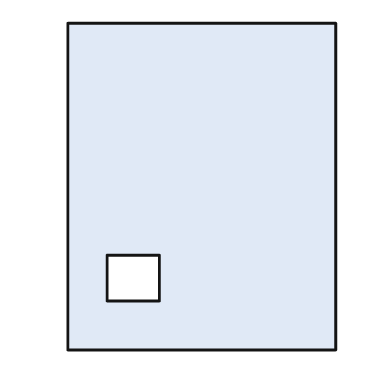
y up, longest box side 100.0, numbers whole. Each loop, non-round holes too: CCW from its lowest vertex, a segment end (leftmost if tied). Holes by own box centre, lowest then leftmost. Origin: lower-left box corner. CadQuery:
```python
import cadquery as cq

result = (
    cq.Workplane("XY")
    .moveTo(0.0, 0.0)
    .lineTo(82.0, 0.0)
    .lineTo(82.0, 100.0)
    .lineTo(0.0, 100.0)
    .close()
    .moveTo(12.0, 15.0)
    .lineTo(28.0, 15.0)
    .lineTo(28.0, 29.0)
    .lineTo(12.0, 29.0)
    .close()
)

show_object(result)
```